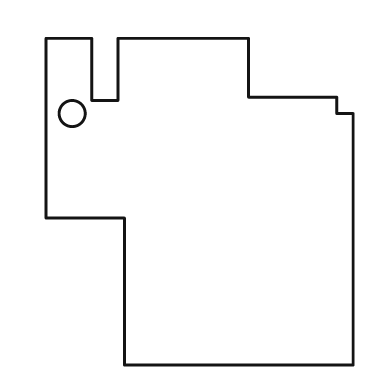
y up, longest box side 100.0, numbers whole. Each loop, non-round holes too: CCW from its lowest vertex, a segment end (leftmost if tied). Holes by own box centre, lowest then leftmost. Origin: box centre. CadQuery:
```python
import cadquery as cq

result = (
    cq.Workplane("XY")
    .moveTo(-23.0, -50.0)
    .lineTo(47.0, -50.0)
    .lineTo(47.0, 27.0)
    .lineTo(42.0, 27.0)
    .lineTo(42.0, 32.0)
    .lineTo(15.0, 32.0)
    .lineTo(15.0, 50.0)
    .lineTo(-25.0, 50.0)
    .lineTo(-25.0, 31.0)
    .lineTo(-33.0, 31.0)
    .lineTo(-33.0, 50.0)
    .lineTo(-47.0, 50.0)
    .lineTo(-47.0, -5.0)
    .lineTo(-23.0, -5.0)
    .close()
    .moveTo(-39.0, 27.0)
    .circle(4.0)
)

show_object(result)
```